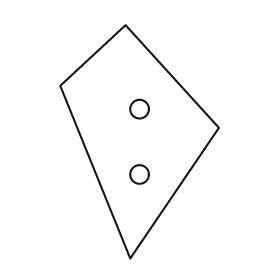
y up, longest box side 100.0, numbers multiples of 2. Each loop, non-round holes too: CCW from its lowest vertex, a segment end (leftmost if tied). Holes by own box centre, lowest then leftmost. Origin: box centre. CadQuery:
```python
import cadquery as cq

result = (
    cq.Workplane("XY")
    .moveTo(-4.0, -50.0)
    .lineTo(34.0, 6.0)
    .lineTo(-6.0, 50.0)
    .lineTo(-34.0, 24.0)
    .close()
    .moveTo(0.0, -14.0)
    .circle(4.0)
    .moveTo(0.0, 14.0)
    .circle(4.0)
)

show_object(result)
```